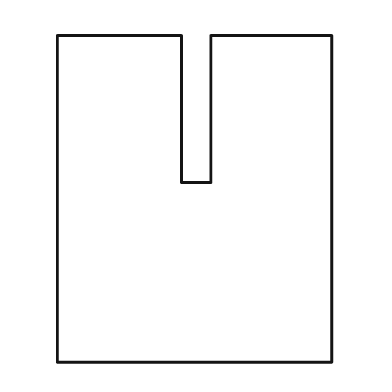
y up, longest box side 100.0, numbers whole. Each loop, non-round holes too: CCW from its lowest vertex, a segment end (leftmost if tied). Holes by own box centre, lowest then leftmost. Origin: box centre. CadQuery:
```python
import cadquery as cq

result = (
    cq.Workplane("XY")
    .moveTo(-42.0, -50.0)
    .lineTo(42.0, -50.0)
    .lineTo(42.0, 50.0)
    .lineTo(5.0, 50.0)
    .lineTo(5.0, 5.0)
    .lineTo(-4.0, 5.0)
    .lineTo(-4.0, 50.0)
    .lineTo(-42.0, 50.0)
    .close()
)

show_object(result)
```